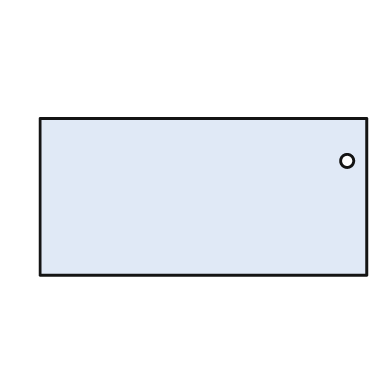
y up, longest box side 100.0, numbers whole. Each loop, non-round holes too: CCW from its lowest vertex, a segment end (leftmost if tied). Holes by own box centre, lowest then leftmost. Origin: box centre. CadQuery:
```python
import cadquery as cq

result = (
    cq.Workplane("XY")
    .moveTo(-50.0, -24.0)
    .lineTo(50.0, -24.0)
    .lineTo(50.0, 24.0)
    .lineTo(-50.0, 24.0)
    .close()
    .moveTo(44.0, 11.0)
    .circle(2.0)
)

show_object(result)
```